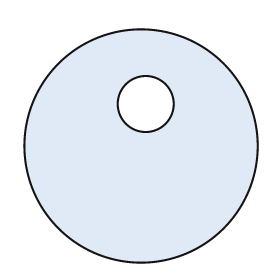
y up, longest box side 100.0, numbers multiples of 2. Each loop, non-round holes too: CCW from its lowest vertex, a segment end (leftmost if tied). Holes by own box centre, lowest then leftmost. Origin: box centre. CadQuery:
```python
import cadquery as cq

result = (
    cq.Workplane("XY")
    .moveTo(0.0, 0.0)
    .circle(50.0)
    .moveTo(2.0, 18.0)
    .circle(12.0)
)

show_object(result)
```